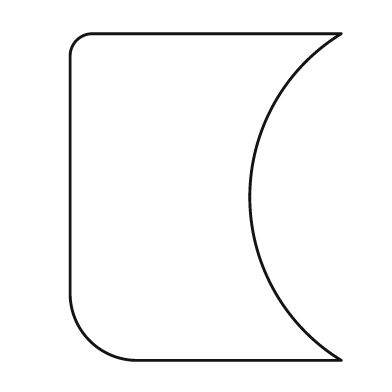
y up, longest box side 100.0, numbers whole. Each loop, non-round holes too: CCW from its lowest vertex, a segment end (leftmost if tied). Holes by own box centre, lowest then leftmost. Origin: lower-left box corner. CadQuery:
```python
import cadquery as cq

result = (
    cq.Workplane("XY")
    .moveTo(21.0, 0.0)
    .lineTo(83.0, 0.0)
    .threePointArc((55.0, 50.0), (83.0, 100.0))
    .lineTo(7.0, 100.0)
    .threePointArc((2.0, 98.0), (0.0, 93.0))
    .lineTo(0.0, 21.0)
    .threePointArc((6.0, 6.0), (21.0, 0.0))
    .close()
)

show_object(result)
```